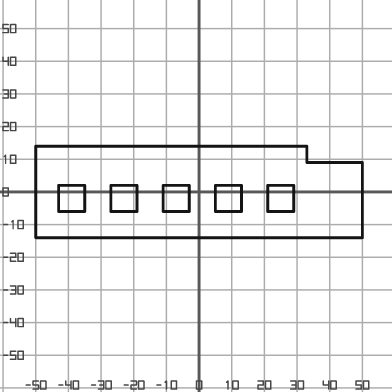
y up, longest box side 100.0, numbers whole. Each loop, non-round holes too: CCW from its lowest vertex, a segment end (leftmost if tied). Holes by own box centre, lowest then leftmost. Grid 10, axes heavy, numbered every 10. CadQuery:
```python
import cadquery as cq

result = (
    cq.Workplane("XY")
    .moveTo(-50.0, -14.0)
    .lineTo(50.0, -14.0)
    .lineTo(50.0, 9.0)
    .lineTo(33.0, 9.0)
    .lineTo(33.0, 14.0)
    .lineTo(-50.0, 14.0)
    .close()
    .moveTo(-43.0, -6.0)
    .lineTo(-35.0, -6.0)
    .lineTo(-35.0, 2.0)
    .lineTo(-43.0, 2.0)
    .close()
    .moveTo(-27.0, -6.0)
    .lineTo(-19.0, -6.0)
    .lineTo(-19.0, 2.0)
    .lineTo(-27.0, 2.0)
    .close()
    .moveTo(-11.0, -6.0)
    .lineTo(-3.0, -6.0)
    .lineTo(-3.0, 2.0)
    .lineTo(-11.0, 2.0)
    .close()
    .moveTo(5.0, -6.0)
    .lineTo(13.0, -6.0)
    .lineTo(13.0, 2.0)
    .lineTo(5.0, 2.0)
    .close()
    .moveTo(21.0, -6.0)
    .lineTo(29.0, -6.0)
    .lineTo(29.0, 2.0)
    .lineTo(21.0, 2.0)
    .close()
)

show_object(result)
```